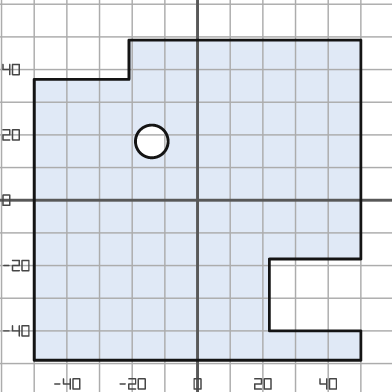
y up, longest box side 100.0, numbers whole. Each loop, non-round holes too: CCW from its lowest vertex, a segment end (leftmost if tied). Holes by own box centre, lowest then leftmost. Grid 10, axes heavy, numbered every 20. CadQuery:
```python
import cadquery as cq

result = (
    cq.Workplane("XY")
    .moveTo(-50.0, -49.0)
    .lineTo(50.0, -49.0)
    .lineTo(50.0, -40.0)
    .lineTo(22.0, -40.0)
    .lineTo(22.0, -18.0)
    .lineTo(50.0, -18.0)
    .lineTo(50.0, 49.0)
    .lineTo(-21.0, 49.0)
    .lineTo(-21.0, 37.0)
    .lineTo(-50.0, 37.0)
    .close()
    .moveTo(-14.0, 18.0)
    .circle(5.0)
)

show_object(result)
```